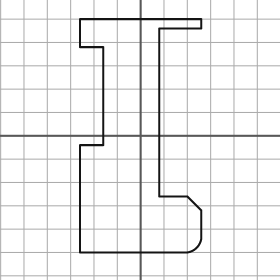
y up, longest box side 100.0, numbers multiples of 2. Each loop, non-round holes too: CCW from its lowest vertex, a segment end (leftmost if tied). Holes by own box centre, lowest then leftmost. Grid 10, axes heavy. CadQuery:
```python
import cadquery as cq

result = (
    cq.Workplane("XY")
    .moveTo(-26.0, -50.0)
    .lineTo(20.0, -50.0)
    .threePointArc((24.0, -48.0), (26.0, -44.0))
    .lineTo(26.0, -32.0)
    .lineTo(20.0, -26.0)
    .lineTo(8.0, -26.0)
    .lineTo(8.0, 46.0)
    .lineTo(26.0, 46.0)
    .lineTo(26.0, 50.0)
    .lineTo(-26.0, 50.0)
    .lineTo(-26.0, 38.0)
    .lineTo(-16.0, 38.0)
    .lineTo(-16.0, -4.0)
    .lineTo(-26.0, -4.0)
    .close()
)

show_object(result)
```